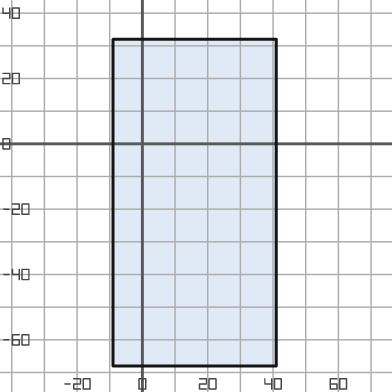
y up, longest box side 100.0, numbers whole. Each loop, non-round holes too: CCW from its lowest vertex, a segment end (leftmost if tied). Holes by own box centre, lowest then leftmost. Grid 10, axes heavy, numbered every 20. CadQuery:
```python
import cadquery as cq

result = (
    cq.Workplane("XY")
    .moveTo(-9.0, -68.0)
    .lineTo(41.0, -68.0)
    .lineTo(41.0, 32.0)
    .lineTo(-9.0, 32.0)
    .close()
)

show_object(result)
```